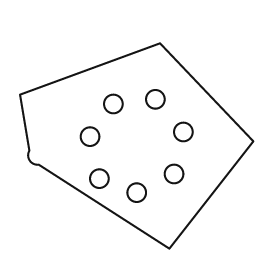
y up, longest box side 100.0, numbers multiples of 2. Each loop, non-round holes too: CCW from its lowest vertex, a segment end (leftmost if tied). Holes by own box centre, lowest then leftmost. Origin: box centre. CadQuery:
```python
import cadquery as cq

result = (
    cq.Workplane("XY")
    .moveTo(14.0, -44.0)
    .lineTo(50.0, 2.0)
    .lineTo(10.0, 44.0)
    .lineTo(-50.0, 22.0)
    .lineTo(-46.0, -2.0)
    .threePointArc((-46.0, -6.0), (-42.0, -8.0))
    .close()
    .moveTo(0.0, -20.0)
    .circle(4.0)
    .moveTo(-16.0, -14.0)
    .circle(4.0)
    .moveTo(16.0, -12.0)
    .circle(4.0)
    .moveTo(-20.0, 4.0)
    .circle(4.0)
    .moveTo(20.0, 6.0)
    .circle(4.0)
    .moveTo(-10.0, 18.0)
    .circle(4.0)
    .moveTo(8.0, 20.0)
    .circle(4.0)
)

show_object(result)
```